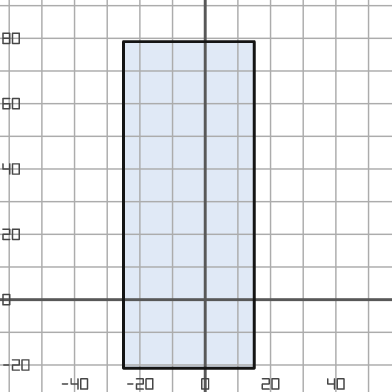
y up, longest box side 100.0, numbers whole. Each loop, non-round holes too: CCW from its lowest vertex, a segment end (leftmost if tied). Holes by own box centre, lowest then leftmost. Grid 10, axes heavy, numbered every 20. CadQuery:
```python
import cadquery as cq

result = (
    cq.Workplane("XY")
    .moveTo(-25.0, -21.0)
    .lineTo(15.0, -21.0)
    .lineTo(15.0, 79.0)
    .lineTo(-25.0, 79.0)
    .close()
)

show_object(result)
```